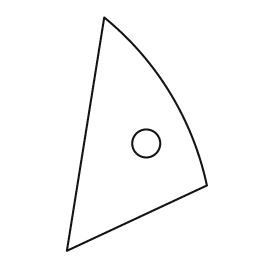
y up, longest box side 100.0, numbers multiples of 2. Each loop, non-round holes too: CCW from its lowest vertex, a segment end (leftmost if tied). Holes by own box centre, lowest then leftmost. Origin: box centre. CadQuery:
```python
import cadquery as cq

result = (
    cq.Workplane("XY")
    .moveTo(-30.0, -50.0)
    .lineTo(30.0, -22.0)
    .threePointArc((14.0, 18.0), (-14.0, 50.0))
    .close()
    .moveTo(4.0, -4.0)
    .circle(6.0)
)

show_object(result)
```